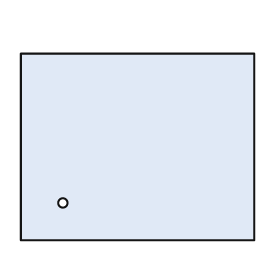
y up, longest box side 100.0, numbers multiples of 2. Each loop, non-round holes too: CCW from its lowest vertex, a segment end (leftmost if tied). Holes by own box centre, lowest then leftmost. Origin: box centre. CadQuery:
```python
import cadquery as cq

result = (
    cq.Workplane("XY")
    .moveTo(-50.0, -40.0)
    .lineTo(50.0, -40.0)
    .lineTo(50.0, 40.0)
    .lineTo(-50.0, 40.0)
    .close()
    .moveTo(-32.0, -24.0)
    .circle(2.0)
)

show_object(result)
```